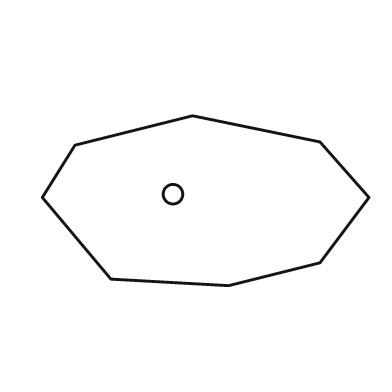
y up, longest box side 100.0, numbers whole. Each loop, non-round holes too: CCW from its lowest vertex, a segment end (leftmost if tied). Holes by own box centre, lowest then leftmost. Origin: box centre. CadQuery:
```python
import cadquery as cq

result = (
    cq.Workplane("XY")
    .moveTo(7.0, -26.0)
    .lineTo(35.0, -19.0)
    .lineTo(50.0, 1.0)
    .lineTo(35.0, 18.0)
    .lineTo(-4.0, 26.0)
    .lineTo(-40.0, 17.0)
    .lineTo(-50.0, 1.0)
    .lineTo(-29.0, -24.0)
    .close()
    .moveTo(-10.0, 2.0)
    .circle(3.0)
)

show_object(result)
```